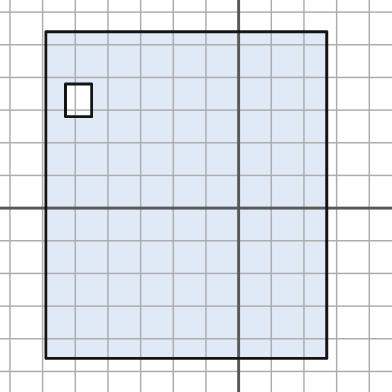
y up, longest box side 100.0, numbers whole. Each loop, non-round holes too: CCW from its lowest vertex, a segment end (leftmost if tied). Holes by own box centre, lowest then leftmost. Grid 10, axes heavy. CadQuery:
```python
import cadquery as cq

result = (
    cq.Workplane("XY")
    .moveTo(-59.0, -46.0)
    .lineTo(27.0, -46.0)
    .lineTo(27.0, 54.0)
    .lineTo(-59.0, 54.0)
    .close()
    .moveTo(-53.0, 28.0)
    .lineTo(-45.0, 28.0)
    .lineTo(-45.0, 38.0)
    .lineTo(-53.0, 38.0)
    .close()
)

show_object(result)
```